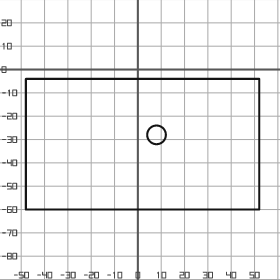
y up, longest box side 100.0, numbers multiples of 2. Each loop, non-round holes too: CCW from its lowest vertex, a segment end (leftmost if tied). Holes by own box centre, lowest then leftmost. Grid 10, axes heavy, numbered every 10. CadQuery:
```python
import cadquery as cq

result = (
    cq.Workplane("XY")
    .moveTo(-48.0, -60.0)
    .lineTo(52.0, -60.0)
    .lineTo(52.0, -4.0)
    .lineTo(-48.0, -4.0)
    .close()
    .moveTo(8.0, -28.0)
    .circle(4.0)
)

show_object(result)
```